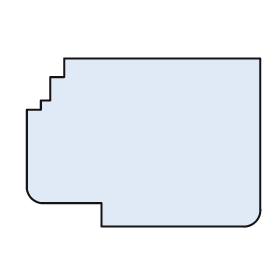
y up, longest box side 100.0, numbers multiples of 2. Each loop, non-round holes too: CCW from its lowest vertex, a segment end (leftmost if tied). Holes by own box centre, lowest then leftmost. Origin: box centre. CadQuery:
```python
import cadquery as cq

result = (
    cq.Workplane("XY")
    .moveTo(-18.0, -36.0)
    .lineTo(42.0, -36.0)
    .threePointArc((48.0, -34.0), (50.0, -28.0))
    .lineTo(50.0, 36.0)
    .lineTo(-34.0, 36.0)
    .lineTo(-34.0, 28.0)
    .lineTo(-40.0, 28.0)
    .lineTo(-40.0, 18.0)
    .lineTo(-44.0, 18.0)
    .lineTo(-44.0, 14.0)
    .lineTo(-50.0, 14.0)
    .lineTo(-50.0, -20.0)
    .threePointArc((-48.0, -24.0), (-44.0, -26.0))
    .lineTo(-18.0, -26.0)
    .close()
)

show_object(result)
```